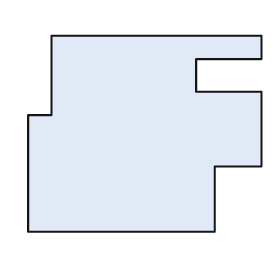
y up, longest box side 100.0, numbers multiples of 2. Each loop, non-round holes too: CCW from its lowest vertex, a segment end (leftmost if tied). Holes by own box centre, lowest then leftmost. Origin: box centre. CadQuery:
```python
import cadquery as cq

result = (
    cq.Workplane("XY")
    .moveTo(-50.0, -42.0)
    .lineTo(30.0, -42.0)
    .lineTo(30.0, -14.0)
    .lineTo(50.0, -14.0)
    .lineTo(50.0, 18.0)
    .lineTo(22.0, 18.0)
    .lineTo(22.0, 32.0)
    .lineTo(50.0, 32.0)
    .lineTo(50.0, 42.0)
    .lineTo(-40.0, 42.0)
    .lineTo(-40.0, 8.0)
    .lineTo(-50.0, 8.0)
    .close()
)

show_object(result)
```